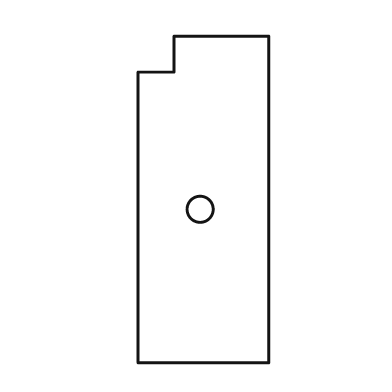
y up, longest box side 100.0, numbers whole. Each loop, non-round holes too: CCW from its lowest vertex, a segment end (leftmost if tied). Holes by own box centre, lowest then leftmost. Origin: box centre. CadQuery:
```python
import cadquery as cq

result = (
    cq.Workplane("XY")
    .moveTo(-20.0, -50.0)
    .lineTo(20.0, -50.0)
    .lineTo(20.0, 50.0)
    .lineTo(-9.0, 50.0)
    .lineTo(-9.0, 39.0)
    .lineTo(-20.0, 39.0)
    .close()
    .moveTo(-1.0, -3.0)
    .circle(4.0)
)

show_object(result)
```